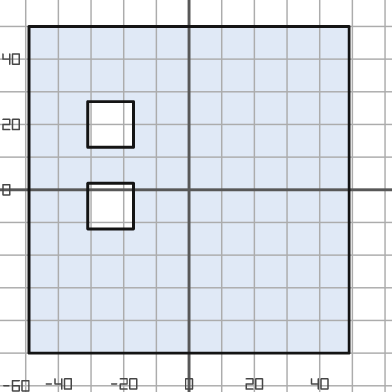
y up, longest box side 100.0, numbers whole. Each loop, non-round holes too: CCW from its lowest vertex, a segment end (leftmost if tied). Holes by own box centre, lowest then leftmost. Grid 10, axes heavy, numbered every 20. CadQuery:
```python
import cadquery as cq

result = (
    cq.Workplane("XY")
    .moveTo(-49.0, -50.0)
    .lineTo(49.0, -50.0)
    .lineTo(49.0, 50.0)
    .lineTo(-49.0, 50.0)
    .close()
    .moveTo(-31.0, -12.0)
    .lineTo(-17.0, -12.0)
    .lineTo(-17.0, 2.0)
    .lineTo(-31.0, 2.0)
    .close()
    .moveTo(-31.0, 13.0)
    .lineTo(-17.0, 13.0)
    .lineTo(-17.0, 27.0)
    .lineTo(-31.0, 27.0)
    .close()
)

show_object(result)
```